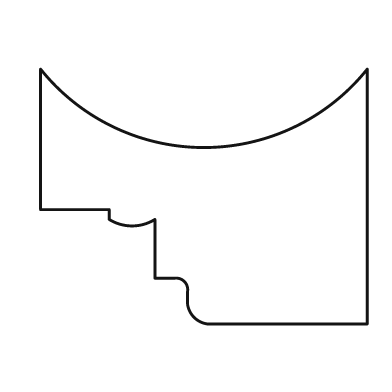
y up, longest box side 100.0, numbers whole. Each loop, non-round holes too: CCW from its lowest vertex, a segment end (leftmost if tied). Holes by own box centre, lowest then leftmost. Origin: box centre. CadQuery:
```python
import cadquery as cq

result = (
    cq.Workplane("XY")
    .moveTo(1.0, -39.0)
    .lineTo(50.0, -39.0)
    .lineTo(50.0, 39.0)
    .threePointArc((0.0, 15.0), (-50.0, 39.0))
    .lineTo(-50.0, -4.0)
    .lineTo(-29.0, -4.0)
    .lineTo(-29.0, -7.0)
    .threePointArc((-22.0, -9.0), (-15.0, -7.0))
    .lineTo(-15.0, -25.0)
    .lineTo(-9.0, -25.0)
    .threePointArc((-6.0, -26.0), (-5.0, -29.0))
    .lineTo(-5.0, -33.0)
    .threePointArc((-3.0, -37.0), (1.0, -39.0))
    .close()
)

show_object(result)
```